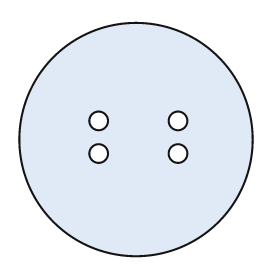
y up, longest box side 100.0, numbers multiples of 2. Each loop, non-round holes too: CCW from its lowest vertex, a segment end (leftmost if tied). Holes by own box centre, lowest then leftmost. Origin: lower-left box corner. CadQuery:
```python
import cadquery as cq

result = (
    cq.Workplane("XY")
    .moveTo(50.0, 50.0)
    .circle(50.0)
    .moveTo(34.0, 44.0)
    .circle(4.0)
    .moveTo(68.0, 44.0)
    .circle(4.0)
    .moveTo(34.0, 58.0)
    .circle(4.0)
    .moveTo(68.0, 58.0)
    .circle(4.0)
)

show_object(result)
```